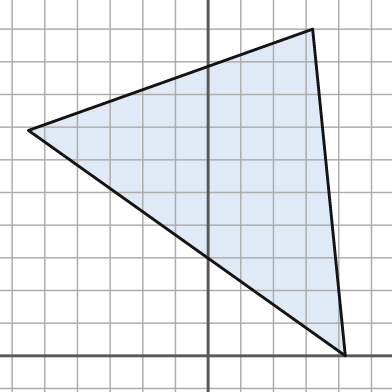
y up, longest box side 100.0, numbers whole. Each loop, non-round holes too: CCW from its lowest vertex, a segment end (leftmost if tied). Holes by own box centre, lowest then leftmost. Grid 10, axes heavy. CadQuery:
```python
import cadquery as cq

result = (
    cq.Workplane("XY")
    .moveTo(42.0, 0.0)
    .lineTo(32.0, 100.0)
    .lineTo(-55.0, 69.0)
    .close()
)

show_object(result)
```